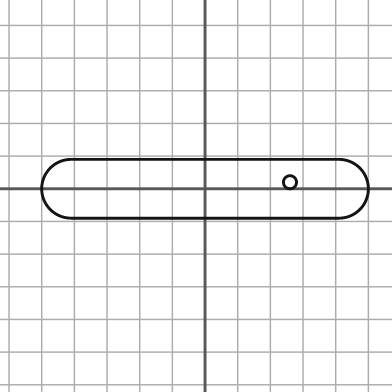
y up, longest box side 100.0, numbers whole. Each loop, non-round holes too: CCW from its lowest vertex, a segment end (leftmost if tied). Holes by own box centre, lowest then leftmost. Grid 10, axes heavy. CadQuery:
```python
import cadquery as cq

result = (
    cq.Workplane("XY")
    .moveTo(-41.0, -9.0)
    .lineTo(41.0, -9.0)
    .threePointArc((50.0, 0.0), (41.0, 9.0))
    .lineTo(-41.0, 9.0)
    .threePointArc((-50.0, 0.0), (-41.0, -9.0))
    .close()
    .moveTo(26.0, 2.0)
    .circle(2.0)
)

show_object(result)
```